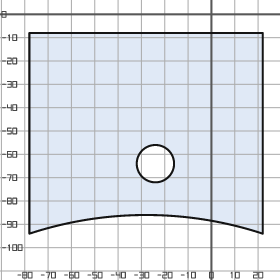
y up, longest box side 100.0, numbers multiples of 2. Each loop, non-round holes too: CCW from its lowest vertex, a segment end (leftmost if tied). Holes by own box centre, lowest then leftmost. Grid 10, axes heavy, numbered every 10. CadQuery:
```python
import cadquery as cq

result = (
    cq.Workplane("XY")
    .moveTo(-78.0, -94.0)
    .threePointArc((-28.0, -86.0), (22.0, -94.0))
    .lineTo(22.0, -8.0)
    .lineTo(-78.0, -8.0)
    .close()
    .moveTo(-24.0, -64.0)
    .circle(8.0)
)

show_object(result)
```